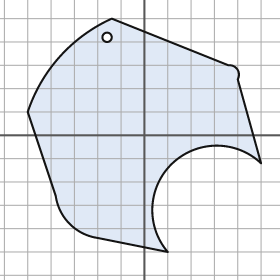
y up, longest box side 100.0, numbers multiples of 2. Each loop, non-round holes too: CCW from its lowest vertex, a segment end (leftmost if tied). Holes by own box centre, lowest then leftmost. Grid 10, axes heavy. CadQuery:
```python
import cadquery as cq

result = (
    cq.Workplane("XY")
    .moveTo(10.0, -50.0)
    .threePointArc((12.0, -12.0), (50.0, -12.0))
    .lineTo(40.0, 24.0)
    .threePointArc((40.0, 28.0), (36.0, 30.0))
    .lineTo(-14.0, 50.0)
    .threePointArc((-36.0, 34.0), (-50.0, 10.0))
    .lineTo(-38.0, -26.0)
    .threePointArc((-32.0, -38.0), (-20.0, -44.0))
    .close()
    .moveTo(-16.0, 42.0)
    .circle(2.0)
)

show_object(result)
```